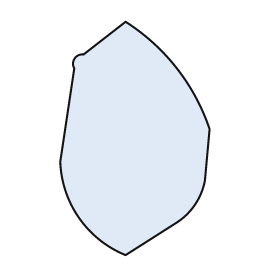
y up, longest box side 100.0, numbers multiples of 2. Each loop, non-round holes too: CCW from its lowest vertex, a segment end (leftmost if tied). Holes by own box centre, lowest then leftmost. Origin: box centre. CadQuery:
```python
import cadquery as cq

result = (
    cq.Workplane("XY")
    .moveTo(-4.0, -50.0)
    .lineTo(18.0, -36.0)
    .threePointArc((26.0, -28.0), (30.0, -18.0))
    .lineTo(32.0, 4.0)
    .threePointArc((18.0, 30.0), (-4.0, 50.0))
    .lineTo(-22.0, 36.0)
    .threePointArc((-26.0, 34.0), (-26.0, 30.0))
    .lineTo(-32.0, -10.0)
    .threePointArc((-24.0, -34.0), (-4.0, -50.0))
    .close()
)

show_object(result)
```